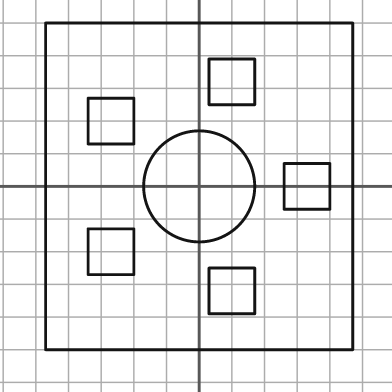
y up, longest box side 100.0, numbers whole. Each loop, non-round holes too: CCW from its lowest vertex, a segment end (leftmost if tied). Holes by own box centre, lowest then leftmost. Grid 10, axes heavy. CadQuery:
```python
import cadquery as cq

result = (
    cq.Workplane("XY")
    .moveTo(-47.0, -50.0)
    .lineTo(47.0, -50.0)
    .lineTo(47.0, 50.0)
    .lineTo(-47.0, 50.0)
    .close()
    .moveTo(3.0, -39.0)
    .lineTo(17.0, -39.0)
    .lineTo(17.0, -25.0)
    .lineTo(3.0, -25.0)
    .close()
    .moveTo(-34.0, -27.0)
    .lineTo(-20.0, -27.0)
    .lineTo(-20.0, -13.0)
    .lineTo(-34.0, -13.0)
    .close()
    .moveTo(0.0, 0.0)
    .circle(17.0)
    .moveTo(26.0, -7.0)
    .lineTo(40.0, -7.0)
    .lineTo(40.0, 7.0)
    .lineTo(26.0, 7.0)
    .close()
    .moveTo(-34.0, 13.0)
    .lineTo(-20.0, 13.0)
    .lineTo(-20.0, 27.0)
    .lineTo(-34.0, 27.0)
    .close()
    .moveTo(3.0, 25.0)
    .lineTo(17.0, 25.0)
    .lineTo(17.0, 39.0)
    .lineTo(3.0, 39.0)
    .close()
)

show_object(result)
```